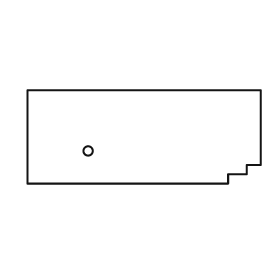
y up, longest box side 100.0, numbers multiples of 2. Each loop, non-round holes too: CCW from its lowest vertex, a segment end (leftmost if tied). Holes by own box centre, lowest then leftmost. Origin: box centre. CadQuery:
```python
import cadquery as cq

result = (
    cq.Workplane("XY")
    .moveTo(-50.0, -20.0)
    .lineTo(36.0, -20.0)
    .lineTo(36.0, -16.0)
    .lineTo(44.0, -16.0)
    .lineTo(44.0, -12.0)
    .lineTo(50.0, -12.0)
    .lineTo(50.0, 20.0)
    .lineTo(-50.0, 20.0)
    .close()
    .moveTo(-24.0, -6.0)
    .circle(2.0)
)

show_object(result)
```